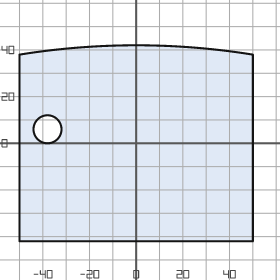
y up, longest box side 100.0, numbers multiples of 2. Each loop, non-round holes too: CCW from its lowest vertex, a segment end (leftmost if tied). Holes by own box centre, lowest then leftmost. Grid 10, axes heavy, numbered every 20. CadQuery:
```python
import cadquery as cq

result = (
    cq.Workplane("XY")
    .moveTo(-50.0, -42.0)
    .lineTo(50.0, -42.0)
    .lineTo(50.0, 38.0)
    .threePointArc((0.0, 42.0), (-50.0, 38.0))
    .close()
    .moveTo(-38.0, 6.0)
    .circle(6.0)
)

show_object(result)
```